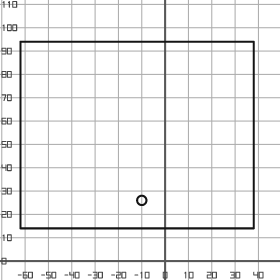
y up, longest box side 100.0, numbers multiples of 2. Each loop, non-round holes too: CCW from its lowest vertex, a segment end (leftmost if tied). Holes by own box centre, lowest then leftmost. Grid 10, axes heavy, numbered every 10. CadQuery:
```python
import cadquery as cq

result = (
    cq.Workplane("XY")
    .moveTo(-62.0, 14.0)
    .lineTo(38.0, 14.0)
    .lineTo(38.0, 94.0)
    .lineTo(-62.0, 94.0)
    .close()
    .moveTo(-10.0, 26.0)
    .circle(2.0)
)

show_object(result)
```